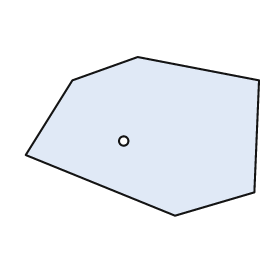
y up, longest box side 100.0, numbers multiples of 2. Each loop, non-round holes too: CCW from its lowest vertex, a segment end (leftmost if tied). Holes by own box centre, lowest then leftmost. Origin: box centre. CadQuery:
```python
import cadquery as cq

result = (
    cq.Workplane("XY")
    .moveTo(14.0, -34.0)
    .lineTo(48.0, -24.0)
    .lineTo(50.0, 24.0)
    .lineTo(-2.0, 34.0)
    .lineTo(-30.0, 24.0)
    .lineTo(-50.0, -8.0)
    .close()
    .moveTo(-8.0, -2.0)
    .circle(2.0)
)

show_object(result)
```